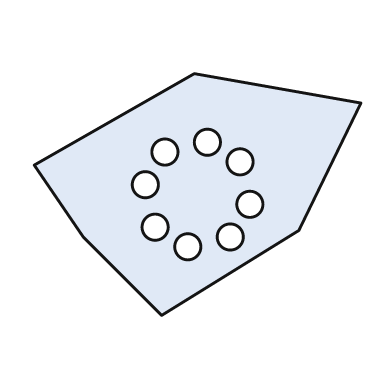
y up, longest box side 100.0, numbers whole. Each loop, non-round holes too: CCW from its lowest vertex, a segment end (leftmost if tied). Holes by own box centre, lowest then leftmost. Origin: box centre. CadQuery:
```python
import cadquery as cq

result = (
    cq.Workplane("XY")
    .moveTo(-11.0, -37.0)
    .lineTo(31.0, -11.0)
    .lineTo(50.0, 28.0)
    .lineTo(-1.0, 37.0)
    .lineTo(-50.0, 9.0)
    .lineTo(-35.0, -13.0)
    .close()
    .moveTo(-3.0, -16.0)
    .circle(4.0)
    .moveTo(10.0, -13.0)
    .circle(4.0)
    .moveTo(-13.0, -10.0)
    .circle(4.0)
    .moveTo(16.0, -3.0)
    .circle(4.0)
    .moveTo(-16.0, 3.0)
    .circle(4.0)
    .moveTo(13.0, 10.0)
    .circle(4.0)
    .moveTo(-10.0, 13.0)
    .circle(4.0)
    .moveTo(3.0, 16.0)
    .circle(4.0)
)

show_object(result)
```